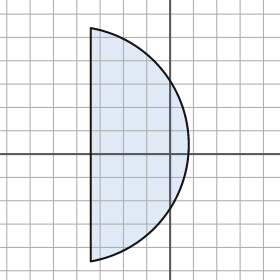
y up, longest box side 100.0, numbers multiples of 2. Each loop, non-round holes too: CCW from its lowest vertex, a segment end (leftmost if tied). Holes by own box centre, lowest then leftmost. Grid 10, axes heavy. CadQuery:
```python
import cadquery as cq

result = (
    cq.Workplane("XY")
    .moveTo(-34.0, -46.0)
    .threePointArc((8.0, 4.0), (-34.0, 54.0))
    .close()
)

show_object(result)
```